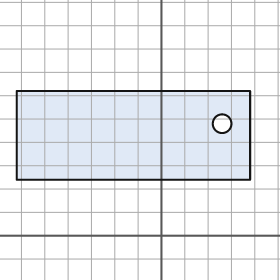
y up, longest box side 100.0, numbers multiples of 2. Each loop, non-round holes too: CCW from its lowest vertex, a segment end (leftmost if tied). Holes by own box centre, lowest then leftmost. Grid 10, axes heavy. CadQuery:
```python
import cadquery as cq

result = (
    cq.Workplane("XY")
    .moveTo(-62.0, 24.0)
    .lineTo(38.0, 24.0)
    .lineTo(38.0, 62.0)
    .lineTo(-62.0, 62.0)
    .close()
    .moveTo(26.0, 48.0)
    .circle(4.0)
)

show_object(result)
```